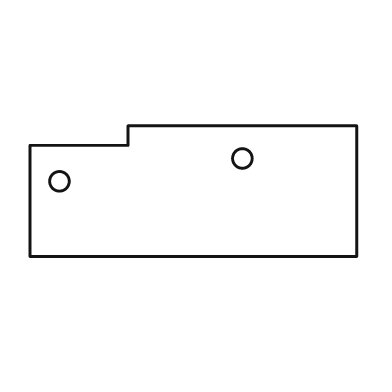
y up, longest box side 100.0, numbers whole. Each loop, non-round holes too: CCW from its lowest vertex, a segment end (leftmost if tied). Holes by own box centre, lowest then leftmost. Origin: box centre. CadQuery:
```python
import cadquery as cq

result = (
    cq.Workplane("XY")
    .moveTo(-50.0, -20.0)
    .lineTo(50.0, -20.0)
    .lineTo(50.0, 20.0)
    .lineTo(-20.0, 20.0)
    .lineTo(-20.0, 14.0)
    .lineTo(-50.0, 14.0)
    .close()
    .moveTo(-41.0, 3.0)
    .circle(3.0)
    .moveTo(15.0, 10.0)
    .circle(3.0)
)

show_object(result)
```